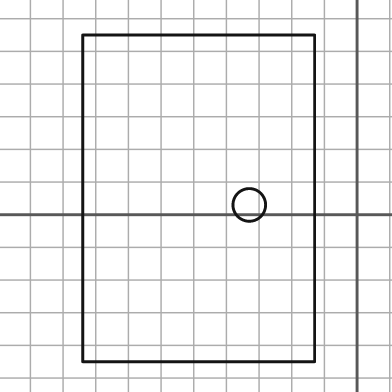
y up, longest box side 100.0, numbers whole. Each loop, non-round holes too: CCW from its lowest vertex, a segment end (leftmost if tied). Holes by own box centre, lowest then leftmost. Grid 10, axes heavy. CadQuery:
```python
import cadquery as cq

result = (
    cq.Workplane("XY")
    .moveTo(-84.0, -45.0)
    .lineTo(-13.0, -45.0)
    .lineTo(-13.0, 55.0)
    .lineTo(-84.0, 55.0)
    .close()
    .moveTo(-33.0, 3.0)
    .circle(5.0)
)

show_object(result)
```